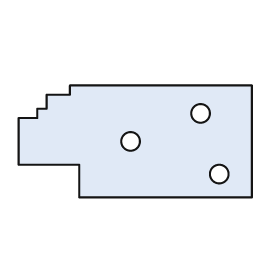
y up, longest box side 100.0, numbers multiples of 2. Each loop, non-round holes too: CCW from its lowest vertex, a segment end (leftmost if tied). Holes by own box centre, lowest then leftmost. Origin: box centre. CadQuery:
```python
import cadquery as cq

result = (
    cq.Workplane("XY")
    .moveTo(-24.0, -24.0)
    .lineTo(50.0, -24.0)
    .lineTo(50.0, 24.0)
    .lineTo(-28.0, 24.0)
    .lineTo(-28.0, 20.0)
    .lineTo(-38.0, 20.0)
    .lineTo(-38.0, 14.0)
    .lineTo(-42.0, 14.0)
    .lineTo(-42.0, 10.0)
    .lineTo(-50.0, 10.0)
    .lineTo(-50.0, -10.0)
    .lineTo(-24.0, -10.0)
    .close()
    .moveTo(36.0, -14.0)
    .circle(4.0)
    .moveTo(-2.0, 0.0)
    .circle(4.0)
    .moveTo(28.0, 12.0)
    .circle(4.0)
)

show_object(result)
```